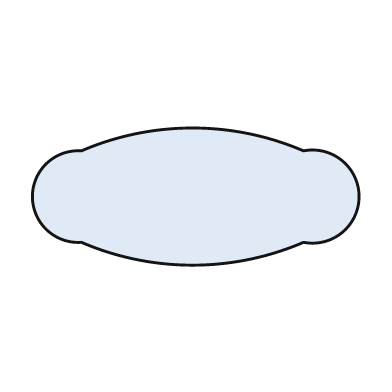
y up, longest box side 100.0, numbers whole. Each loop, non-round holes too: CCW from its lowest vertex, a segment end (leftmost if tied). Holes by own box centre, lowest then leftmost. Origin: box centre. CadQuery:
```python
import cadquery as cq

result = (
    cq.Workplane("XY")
    .moveTo(-35.0, -14.0)
    .threePointArc((-1.0, -21.0), (33.0, -14.0))
    .threePointArc((50.0, 0.0), (33.0, 14.0))
    .threePointArc((-1.0, 21.0), (-35.0, 14.0))
    .threePointArc((-50.0, 0.0), (-35.0, -14.0))
    .close()
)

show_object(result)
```